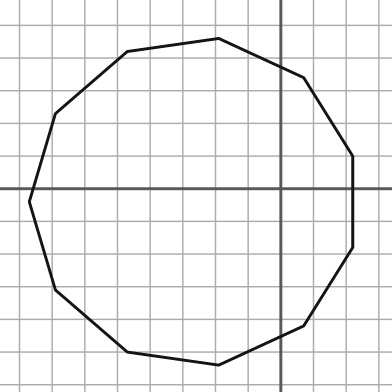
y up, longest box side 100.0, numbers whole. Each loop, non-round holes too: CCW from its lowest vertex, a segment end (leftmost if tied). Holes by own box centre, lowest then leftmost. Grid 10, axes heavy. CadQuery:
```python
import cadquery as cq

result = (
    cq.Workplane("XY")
    .moveTo(-19.0, -54.0)
    .lineTo(7.0, -42.0)
    .lineTo(22.0, -18.0)
    .lineTo(22.0, 10.0)
    .lineTo(7.0, 34.0)
    .lineTo(-19.0, 46.0)
    .lineTo(-47.0, 42.0)
    .lineTo(-69.0, 23.0)
    .lineTo(-77.0, -4.0)
    .lineTo(-69.0, -31.0)
    .lineTo(-47.0, -50.0)
    .close()
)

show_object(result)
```